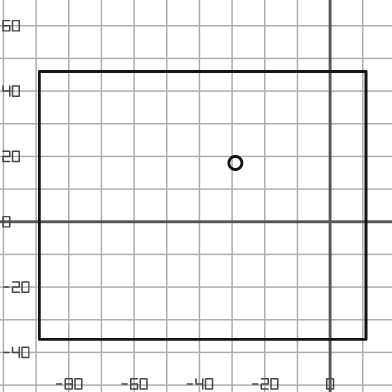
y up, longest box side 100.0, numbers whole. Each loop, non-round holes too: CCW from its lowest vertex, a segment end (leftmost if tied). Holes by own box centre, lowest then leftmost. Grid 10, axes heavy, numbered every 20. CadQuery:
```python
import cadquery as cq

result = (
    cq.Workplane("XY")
    .moveTo(-89.0, -36.0)
    .lineTo(11.0, -36.0)
    .lineTo(11.0, 46.0)
    .lineTo(-89.0, 46.0)
    .close()
    .moveTo(-29.0, 18.0)
    .circle(2.0)
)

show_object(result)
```